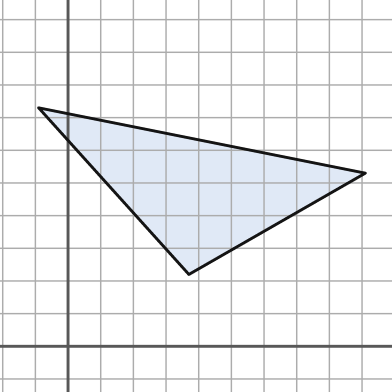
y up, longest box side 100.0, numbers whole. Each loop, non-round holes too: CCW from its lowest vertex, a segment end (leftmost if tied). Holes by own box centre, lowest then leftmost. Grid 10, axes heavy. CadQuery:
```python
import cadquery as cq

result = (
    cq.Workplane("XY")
    .moveTo(37.0, 22.0)
    .lineTo(91.0, 53.0)
    .lineTo(-9.0, 73.0)
    .close()
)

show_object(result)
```